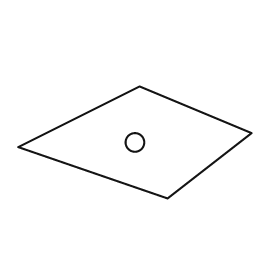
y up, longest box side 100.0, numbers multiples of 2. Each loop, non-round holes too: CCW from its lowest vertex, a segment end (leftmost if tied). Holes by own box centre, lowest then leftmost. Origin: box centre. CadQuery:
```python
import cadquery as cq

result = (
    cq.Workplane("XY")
    .moveTo(14.0, -24.0)
    .lineTo(50.0, 4.0)
    .lineTo(2.0, 24.0)
    .lineTo(-50.0, -2.0)
    .close()
    .moveTo(0.0, 0.0)
    .circle(4.0)
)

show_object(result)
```